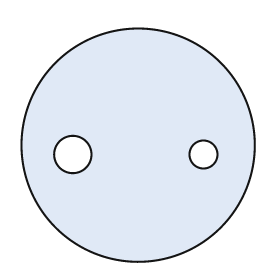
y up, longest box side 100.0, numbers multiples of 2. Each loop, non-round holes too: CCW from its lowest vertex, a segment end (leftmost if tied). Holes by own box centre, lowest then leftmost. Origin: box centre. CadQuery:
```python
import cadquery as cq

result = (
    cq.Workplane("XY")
    .moveTo(0.0, 0.0)
    .circle(50.0)
    .moveTo(-28.0, -4.0)
    .circle(8.0)
    .moveTo(28.0, -4.0)
    .circle(6.0)
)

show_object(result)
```